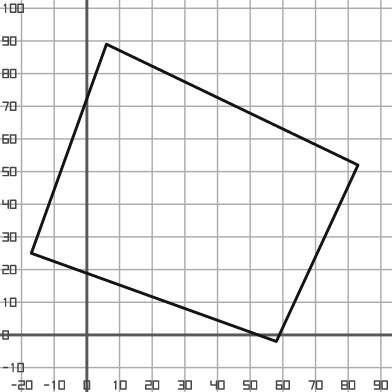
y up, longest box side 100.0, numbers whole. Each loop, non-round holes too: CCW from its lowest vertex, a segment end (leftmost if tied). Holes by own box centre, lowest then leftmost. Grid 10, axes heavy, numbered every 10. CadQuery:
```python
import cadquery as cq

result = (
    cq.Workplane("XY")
    .moveTo(58.0, -2.0)
    .lineTo(83.0, 52.0)
    .lineTo(6.0, 89.0)
    .lineTo(-17.0, 25.0)
    .close()
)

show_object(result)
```